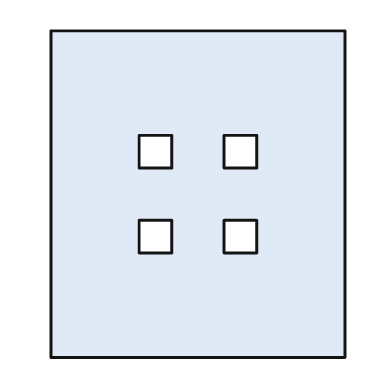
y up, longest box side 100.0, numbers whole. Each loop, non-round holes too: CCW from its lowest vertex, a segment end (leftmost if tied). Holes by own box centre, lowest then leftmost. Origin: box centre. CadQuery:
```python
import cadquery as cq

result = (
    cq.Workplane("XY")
    .moveTo(-45.0, -50.0)
    .lineTo(45.0, -50.0)
    .lineTo(45.0, 50.0)
    .lineTo(-45.0, 50.0)
    .close()
    .moveTo(-18.0, -18.0)
    .lineTo(-8.0, -18.0)
    .lineTo(-8.0, -8.0)
    .lineTo(-18.0, -8.0)
    .close()
    .moveTo(8.0, -18.0)
    .lineTo(18.0, -18.0)
    .lineTo(18.0, -8.0)
    .lineTo(8.0, -8.0)
    .close()
    .moveTo(-18.0, 8.0)
    .lineTo(-8.0, 8.0)
    .lineTo(-8.0, 18.0)
    .lineTo(-18.0, 18.0)
    .close()
    .moveTo(8.0, 8.0)
    .lineTo(18.0, 8.0)
    .lineTo(18.0, 18.0)
    .lineTo(8.0, 18.0)
    .close()
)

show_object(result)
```